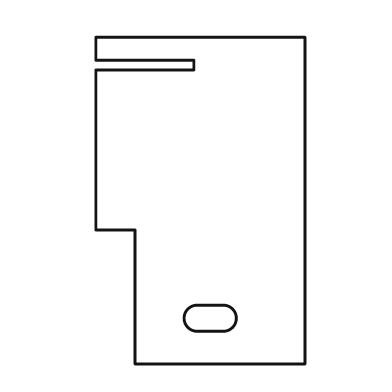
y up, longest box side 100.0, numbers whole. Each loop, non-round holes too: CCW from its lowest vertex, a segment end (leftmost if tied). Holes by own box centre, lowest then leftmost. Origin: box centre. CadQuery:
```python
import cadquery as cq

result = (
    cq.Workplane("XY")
    .moveTo(-20.0, -50.0)
    .lineTo(32.0, -50.0)
    .lineTo(32.0, 50.0)
    .lineTo(-32.0, 50.0)
    .lineTo(-32.0, 43.0)
    .lineTo(-2.0, 43.0)
    .lineTo(-2.0, 40.0)
    .lineTo(-32.0, 40.0)
    .lineTo(-32.0, -9.0)
    .lineTo(-20.0, -9.0)
    .close()
    .moveTo(-1.0, -40.0)
    .lineTo(7.0, -40.0)
    .threePointArc((11.0, -36.0), (7.0, -32.0))
    .lineTo(-1.0, -32.0)
    .threePointArc((-5.0, -36.0), (-1.0, -40.0))
    .close()
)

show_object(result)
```